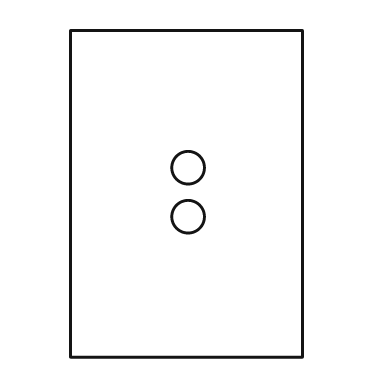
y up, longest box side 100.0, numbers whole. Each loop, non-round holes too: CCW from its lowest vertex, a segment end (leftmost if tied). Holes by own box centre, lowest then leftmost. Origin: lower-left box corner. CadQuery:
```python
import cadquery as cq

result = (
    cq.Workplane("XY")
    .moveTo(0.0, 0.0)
    .lineTo(71.0, 0.0)
    .lineTo(71.0, 100.0)
    .lineTo(0.0, 100.0)
    .close()
    .moveTo(36.0, 43.0)
    .circle(5.0)
    .moveTo(36.0, 58.0)
    .circle(5.0)
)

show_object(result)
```